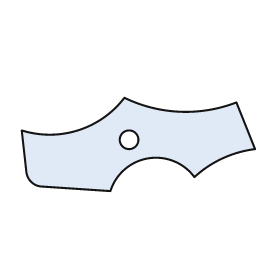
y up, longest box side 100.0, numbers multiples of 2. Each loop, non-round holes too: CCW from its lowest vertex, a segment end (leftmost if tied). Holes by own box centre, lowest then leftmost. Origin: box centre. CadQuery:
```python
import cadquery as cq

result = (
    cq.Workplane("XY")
    .moveTo(-12.0, -20.0)
    .threePointArc((4.0, -6.0), (24.0, -14.0))
    .threePointArc((36.0, -6.0), (50.0, -2.0))
    .lineTo(42.0, 18.0)
    .threePointArc((18.0, 14.0), (-6.0, 20.0))
    .threePointArc((-26.0, 6.0), (-50.0, 6.0))
    .lineTo(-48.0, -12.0)
    .threePointArc((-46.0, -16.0), (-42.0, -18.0))
    .close()
    .moveTo(-4.0, 2.0)
    .circle(4.0)
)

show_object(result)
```